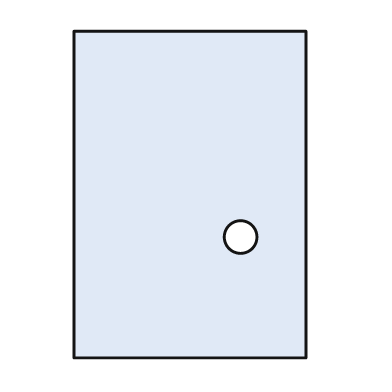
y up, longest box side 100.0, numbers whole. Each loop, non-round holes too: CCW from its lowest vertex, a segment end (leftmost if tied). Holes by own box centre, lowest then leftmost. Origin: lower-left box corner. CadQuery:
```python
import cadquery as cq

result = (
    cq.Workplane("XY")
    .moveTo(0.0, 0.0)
    .lineTo(71.0, 0.0)
    .lineTo(71.0, 100.0)
    .lineTo(0.0, 100.0)
    .close()
    .moveTo(51.0, 37.0)
    .circle(5.0)
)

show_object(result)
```